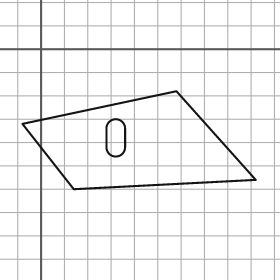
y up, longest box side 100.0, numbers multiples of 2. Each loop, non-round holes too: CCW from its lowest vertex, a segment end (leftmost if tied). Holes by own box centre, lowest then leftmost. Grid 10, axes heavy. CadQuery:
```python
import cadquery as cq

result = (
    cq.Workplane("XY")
    .moveTo(14.0, -60.0)
    .lineTo(92.0, -56.0)
    .lineTo(58.0, -18.0)
    .lineTo(-8.0, -32.0)
    .close()
    .moveTo(28.0, -42.0)
    .threePointArc((32.0, -46.0), (36.0, -42.0))
    .lineTo(36.0, -34.0)
    .threePointArc((32.0, -30.0), (28.0, -34.0))
    .close()
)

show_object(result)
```